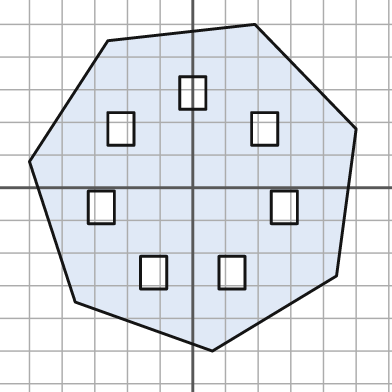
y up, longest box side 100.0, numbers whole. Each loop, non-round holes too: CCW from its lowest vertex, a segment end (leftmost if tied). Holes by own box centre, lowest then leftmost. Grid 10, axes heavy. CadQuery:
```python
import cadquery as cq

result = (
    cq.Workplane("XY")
    .moveTo(6.0, -50.0)
    .lineTo(44.0, -27.0)
    .lineTo(50.0, 18.0)
    .lineTo(19.0, 50.0)
    .lineTo(-26.0, 45.0)
    .lineTo(-50.0, 8.0)
    .lineTo(-36.0, -35.0)
    .close()
    .moveTo(-16.0, -31.0)
    .lineTo(-8.0, -31.0)
    .lineTo(-8.0, -21.0)
    .lineTo(-16.0, -21.0)
    .close()
    .moveTo(8.0, -31.0)
    .lineTo(16.0, -31.0)
    .lineTo(16.0, -21.0)
    .lineTo(8.0, -21.0)
    .close()
    .moveTo(-32.0, -11.0)
    .lineTo(-24.0, -11.0)
    .lineTo(-24.0, -1.0)
    .lineTo(-32.0, -1.0)
    .close()
    .moveTo(24.0, -11.0)
    .lineTo(32.0, -11.0)
    .lineTo(32.0, -1.0)
    .lineTo(24.0, -1.0)
    .close()
    .moveTo(-26.0, 13.0)
    .lineTo(-18.0, 13.0)
    .lineTo(-18.0, 23.0)
    .lineTo(-26.0, 23.0)
    .close()
    .moveTo(18.0, 13.0)
    .lineTo(26.0, 13.0)
    .lineTo(26.0, 23.0)
    .lineTo(18.0, 23.0)
    .close()
    .moveTo(-4.0, 24.0)
    .lineTo(4.0, 24.0)
    .lineTo(4.0, 34.0)
    .lineTo(-4.0, 34.0)
    .close()
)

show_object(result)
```